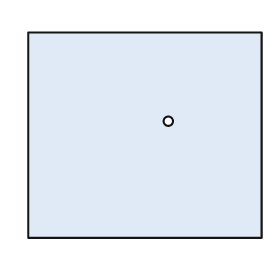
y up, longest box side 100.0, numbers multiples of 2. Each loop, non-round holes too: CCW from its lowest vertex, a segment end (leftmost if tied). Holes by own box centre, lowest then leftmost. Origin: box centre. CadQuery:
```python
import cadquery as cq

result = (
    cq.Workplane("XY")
    .moveTo(-50.0, -44.0)
    .lineTo(50.0, -44.0)
    .lineTo(50.0, 44.0)
    .lineTo(-50.0, 44.0)
    .close()
    .moveTo(10.0, 6.0)
    .circle(2.0)
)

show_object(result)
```